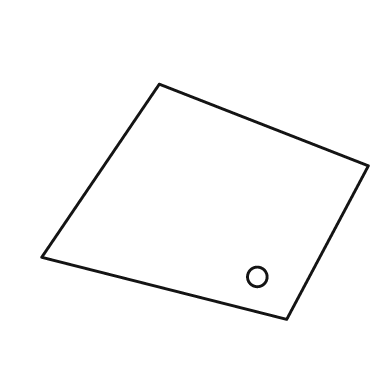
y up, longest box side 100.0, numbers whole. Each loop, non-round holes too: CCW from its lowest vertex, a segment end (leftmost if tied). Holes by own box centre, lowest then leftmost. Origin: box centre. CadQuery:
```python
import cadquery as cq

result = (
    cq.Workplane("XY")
    .moveTo(25.0, -36.0)
    .lineTo(50.0, 11.0)
    .lineTo(-14.0, 36.0)
    .lineTo(-50.0, -17.0)
    .close()
    .moveTo(16.0, -23.0)
    .circle(3.0)
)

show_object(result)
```